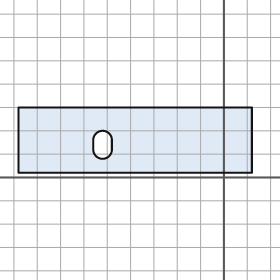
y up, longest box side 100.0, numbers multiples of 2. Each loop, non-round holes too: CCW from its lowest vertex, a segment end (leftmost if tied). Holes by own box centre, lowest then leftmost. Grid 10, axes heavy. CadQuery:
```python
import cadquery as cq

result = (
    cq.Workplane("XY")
    .moveTo(-88.0, 2.0)
    .lineTo(12.0, 2.0)
    .lineTo(12.0, 30.0)
    .lineTo(-88.0, 30.0)
    .close()
    .moveTo(-56.0, 12.0)
    .threePointArc((-52.0, 8.0), (-48.0, 12.0))
    .lineTo(-48.0, 16.0)
    .threePointArc((-52.0, 20.0), (-56.0, 16.0))
    .close()
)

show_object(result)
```